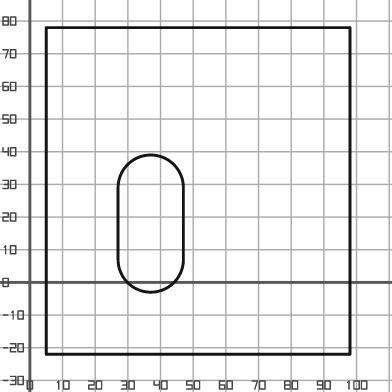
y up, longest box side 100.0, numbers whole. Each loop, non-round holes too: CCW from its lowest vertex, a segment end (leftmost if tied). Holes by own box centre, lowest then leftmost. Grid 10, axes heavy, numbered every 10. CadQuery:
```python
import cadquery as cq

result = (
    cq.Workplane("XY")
    .moveTo(5.0, -22.0)
    .lineTo(98.0, -22.0)
    .lineTo(98.0, 78.0)
    .lineTo(5.0, 78.0)
    .close()
    .moveTo(27.0, 7.0)
    .threePointArc((37.0, -3.0), (47.0, 7.0))
    .lineTo(47.0, 29.0)
    .threePointArc((37.0, 39.0), (27.0, 29.0))
    .close()
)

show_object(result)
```